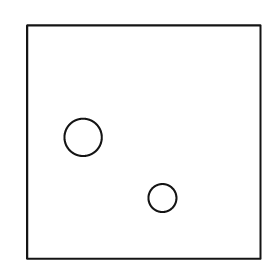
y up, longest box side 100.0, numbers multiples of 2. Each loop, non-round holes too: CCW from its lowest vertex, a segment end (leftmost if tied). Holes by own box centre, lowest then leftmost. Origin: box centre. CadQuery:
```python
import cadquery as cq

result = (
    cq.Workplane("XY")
    .moveTo(-50.0, -50.0)
    .lineTo(50.0, -50.0)
    .lineTo(50.0, 50.0)
    .lineTo(-50.0, 50.0)
    .close()
    .moveTo(8.0, -24.0)
    .circle(6.0)
    .moveTo(-26.0, 2.0)
    .circle(8.0)
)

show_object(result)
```